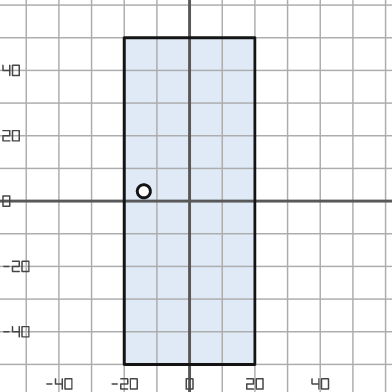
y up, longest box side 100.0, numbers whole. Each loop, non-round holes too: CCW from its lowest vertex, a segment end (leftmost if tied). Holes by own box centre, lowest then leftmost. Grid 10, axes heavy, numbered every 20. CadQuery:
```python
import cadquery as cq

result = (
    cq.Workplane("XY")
    .moveTo(-20.0, -50.0)
    .lineTo(20.0, -50.0)
    .lineTo(20.0, 50.0)
    .lineTo(-20.0, 50.0)
    .close()
    .moveTo(-14.0, 3.0)
    .circle(2.0)
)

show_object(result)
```